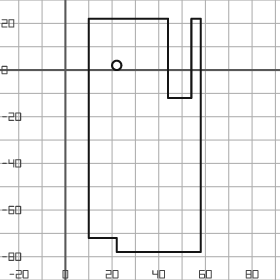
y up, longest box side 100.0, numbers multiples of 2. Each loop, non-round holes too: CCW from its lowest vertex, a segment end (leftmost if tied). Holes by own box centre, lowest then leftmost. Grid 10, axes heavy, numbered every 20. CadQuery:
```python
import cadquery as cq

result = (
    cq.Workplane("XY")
    .moveTo(22.0, -78.0)
    .lineTo(58.0, -78.0)
    .lineTo(58.0, 22.0)
    .lineTo(54.0, 22.0)
    .lineTo(54.0, -12.0)
    .lineTo(44.0, -12.0)
    .lineTo(44.0, 22.0)
    .lineTo(10.0, 22.0)
    .lineTo(10.0, -72.0)
    .lineTo(22.0, -72.0)
    .close()
    .moveTo(22.0, 2.0)
    .circle(2.0)
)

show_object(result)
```